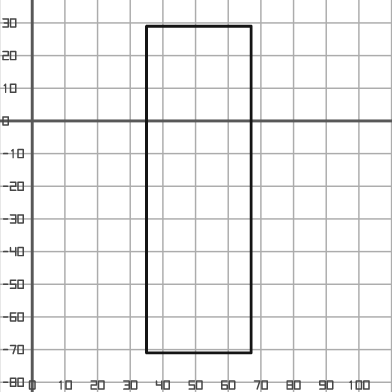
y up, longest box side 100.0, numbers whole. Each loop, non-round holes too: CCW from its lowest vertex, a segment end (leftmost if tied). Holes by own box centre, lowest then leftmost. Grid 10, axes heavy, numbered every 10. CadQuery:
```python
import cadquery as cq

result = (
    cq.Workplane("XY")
    .moveTo(35.0, -71.0)
    .lineTo(67.0, -71.0)
    .lineTo(67.0, 29.0)
    .lineTo(35.0, 29.0)
    .close()
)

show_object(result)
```